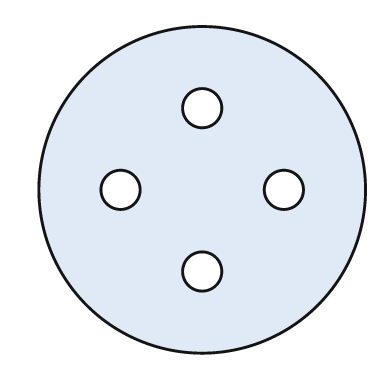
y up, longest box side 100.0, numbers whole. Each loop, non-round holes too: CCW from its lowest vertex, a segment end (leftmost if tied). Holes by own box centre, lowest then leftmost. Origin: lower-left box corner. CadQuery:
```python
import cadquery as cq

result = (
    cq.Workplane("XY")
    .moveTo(50.0, 50.0)
    .circle(50.0)
    .moveTo(50.0, 25.0)
    .circle(6.0)
    .moveTo(25.0, 50.0)
    .circle(6.0)
    .moveTo(75.0, 50.0)
    .circle(6.0)
    .moveTo(50.0, 75.0)
    .circle(6.0)
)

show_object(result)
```